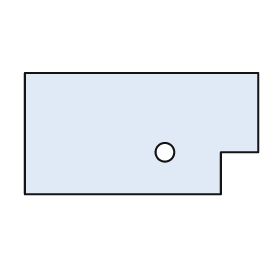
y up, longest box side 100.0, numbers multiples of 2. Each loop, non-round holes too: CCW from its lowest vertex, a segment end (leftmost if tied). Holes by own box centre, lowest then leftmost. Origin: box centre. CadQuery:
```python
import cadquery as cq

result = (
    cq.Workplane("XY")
    .moveTo(-50.0, -26.0)
    .lineTo(34.0, -26.0)
    .lineTo(34.0, -8.0)
    .lineTo(50.0, -8.0)
    .lineTo(50.0, 26.0)
    .lineTo(-50.0, 26.0)
    .close()
    .moveTo(10.0, -8.0)
    .circle(4.0)
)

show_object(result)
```